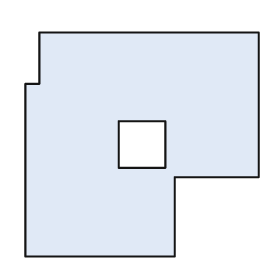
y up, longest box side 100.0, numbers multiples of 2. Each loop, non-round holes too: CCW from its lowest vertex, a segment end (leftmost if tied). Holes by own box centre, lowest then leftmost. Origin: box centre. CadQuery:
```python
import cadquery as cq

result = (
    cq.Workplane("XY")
    .moveTo(-50.0, -48.0)
    .lineTo(14.0, -48.0)
    .lineTo(14.0, -14.0)
    .lineTo(50.0, -14.0)
    .lineTo(50.0, 48.0)
    .lineTo(-44.0, 48.0)
    .lineTo(-44.0, 26.0)
    .lineTo(-50.0, 26.0)
    .close()
    .moveTo(-10.0, -10.0)
    .lineTo(10.0, -10.0)
    .lineTo(10.0, 10.0)
    .lineTo(-10.0, 10.0)
    .close()
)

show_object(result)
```